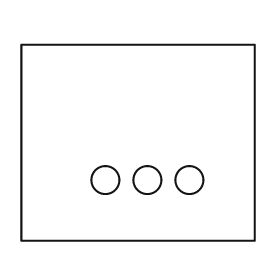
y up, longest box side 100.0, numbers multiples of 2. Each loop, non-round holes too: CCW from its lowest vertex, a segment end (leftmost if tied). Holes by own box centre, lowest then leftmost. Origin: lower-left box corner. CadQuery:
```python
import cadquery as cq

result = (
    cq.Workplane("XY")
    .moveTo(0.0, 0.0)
    .lineTo(100.0, 0.0)
    .lineTo(100.0, 84.0)
    .lineTo(0.0, 84.0)
    .close()
    .moveTo(36.0, 26.0)
    .circle(6.0)
    .moveTo(54.0, 26.0)
    .circle(6.0)
    .moveTo(72.0, 26.0)
    .circle(6.0)
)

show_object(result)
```